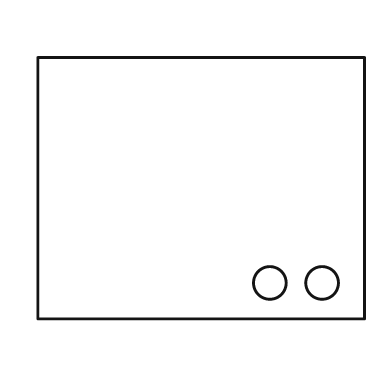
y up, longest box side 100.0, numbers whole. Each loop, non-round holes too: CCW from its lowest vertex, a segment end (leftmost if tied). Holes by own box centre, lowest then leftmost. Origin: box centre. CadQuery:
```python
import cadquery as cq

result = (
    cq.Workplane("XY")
    .moveTo(-50.0, -40.0)
    .lineTo(50.0, -40.0)
    .lineTo(50.0, 40.0)
    .lineTo(-50.0, 40.0)
    .close()
    .moveTo(21.0, -29.0)
    .circle(5.0)
    .moveTo(37.0, -29.0)
    .circle(5.0)
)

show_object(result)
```